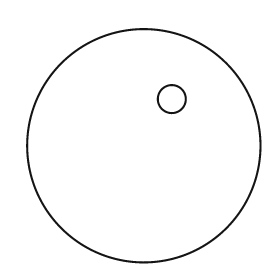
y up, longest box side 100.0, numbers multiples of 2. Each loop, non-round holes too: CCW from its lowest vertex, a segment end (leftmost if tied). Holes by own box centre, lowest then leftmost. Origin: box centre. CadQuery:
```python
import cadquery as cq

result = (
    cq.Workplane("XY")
    .moveTo(0.0, 0.0)
    .circle(50.0)
    .moveTo(12.0, 20.0)
    .circle(6.0)
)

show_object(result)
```